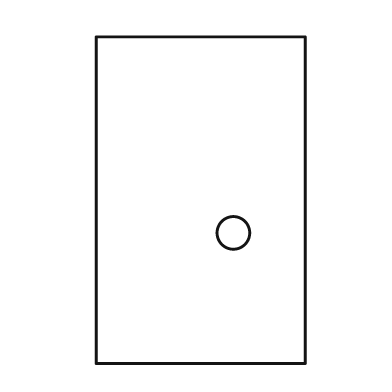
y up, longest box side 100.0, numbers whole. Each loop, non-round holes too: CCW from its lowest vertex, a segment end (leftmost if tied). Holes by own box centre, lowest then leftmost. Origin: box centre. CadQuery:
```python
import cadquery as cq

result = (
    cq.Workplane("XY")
    .moveTo(-32.0, -50.0)
    .lineTo(32.0, -50.0)
    .lineTo(32.0, 50.0)
    .lineTo(-32.0, 50.0)
    .close()
    .moveTo(10.0, -10.0)
    .circle(5.0)
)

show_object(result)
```